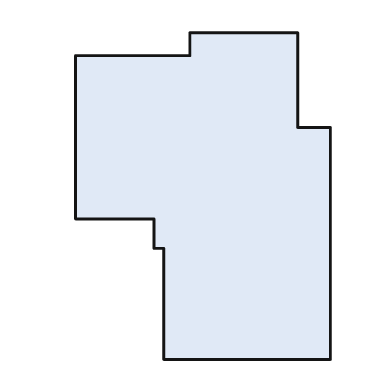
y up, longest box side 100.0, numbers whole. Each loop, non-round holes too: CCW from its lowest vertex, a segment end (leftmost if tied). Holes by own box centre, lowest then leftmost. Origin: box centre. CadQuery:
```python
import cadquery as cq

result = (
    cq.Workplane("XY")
    .moveTo(-12.0, -50.0)
    .lineTo(39.0, -50.0)
    .lineTo(39.0, 21.0)
    .lineTo(29.0, 21.0)
    .lineTo(29.0, 50.0)
    .lineTo(-4.0, 50.0)
    .lineTo(-4.0, 43.0)
    .lineTo(-39.0, 43.0)
    .lineTo(-39.0, -7.0)
    .lineTo(-15.0, -7.0)
    .lineTo(-15.0, -16.0)
    .lineTo(-12.0, -16.0)
    .close()
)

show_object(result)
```